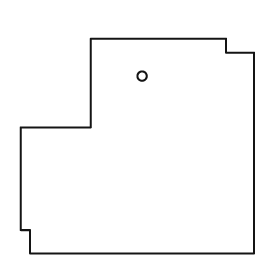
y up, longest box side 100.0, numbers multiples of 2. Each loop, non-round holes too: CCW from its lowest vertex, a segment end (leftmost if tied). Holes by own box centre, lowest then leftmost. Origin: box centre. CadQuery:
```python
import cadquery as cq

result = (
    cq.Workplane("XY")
    .moveTo(-46.0, -46.0)
    .lineTo(50.0, -46.0)
    .lineTo(50.0, 40.0)
    .lineTo(38.0, 40.0)
    .lineTo(38.0, 46.0)
    .lineTo(-20.0, 46.0)
    .lineTo(-20.0, 8.0)
    .lineTo(-50.0, 8.0)
    .lineTo(-50.0, -36.0)
    .lineTo(-46.0, -36.0)
    .close()
    .moveTo(2.0, 30.0)
    .circle(2.0)
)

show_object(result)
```